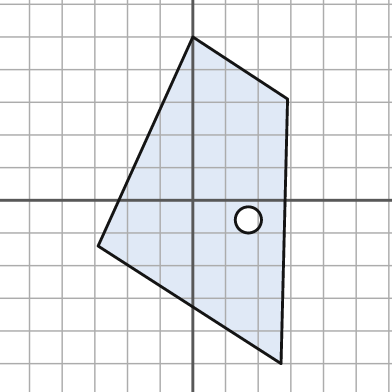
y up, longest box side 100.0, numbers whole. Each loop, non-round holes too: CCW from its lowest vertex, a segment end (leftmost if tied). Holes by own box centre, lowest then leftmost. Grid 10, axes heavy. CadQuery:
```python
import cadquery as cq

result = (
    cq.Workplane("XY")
    .moveTo(27.0, -50.0)
    .lineTo(29.0, 31.0)
    .lineTo(0.0, 50.0)
    .lineTo(-29.0, -14.0)
    .close()
    .moveTo(17.0, -6.0)
    .circle(4.0)
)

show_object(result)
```